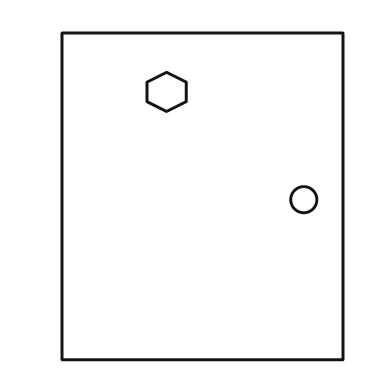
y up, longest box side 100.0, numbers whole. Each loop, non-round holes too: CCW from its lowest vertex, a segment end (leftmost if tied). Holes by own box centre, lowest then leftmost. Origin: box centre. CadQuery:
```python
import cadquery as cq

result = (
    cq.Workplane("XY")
    .moveTo(-43.0, -50.0)
    .lineTo(43.0, -50.0)
    .lineTo(43.0, 50.0)
    .lineTo(-43.0, 50.0)
    .close()
    .moveTo(31.0, -1.0)
    .circle(4.0)
    .moveTo(-11.0, 26.0)
    .lineTo(-5.0, 29.0)
    .lineTo(-5.0, 35.0)
    .lineTo(-11.0, 38.0)
    .lineTo(-17.0, 35.0)
    .lineTo(-17.0, 29.0)
    .close()
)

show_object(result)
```